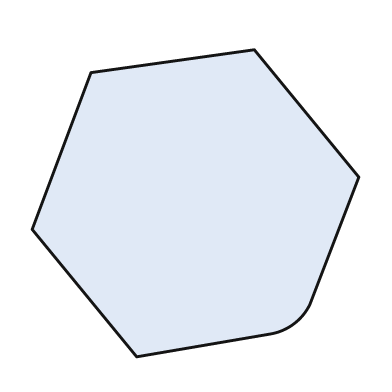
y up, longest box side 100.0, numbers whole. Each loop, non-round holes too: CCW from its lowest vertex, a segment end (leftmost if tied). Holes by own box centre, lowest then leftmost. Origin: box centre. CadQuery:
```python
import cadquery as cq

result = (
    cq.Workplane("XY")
    .moveTo(-18.0, -47.0)
    .lineTo(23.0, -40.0)
    .threePointArc((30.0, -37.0), (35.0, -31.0))
    .lineTo(50.0, 8.0)
    .lineTo(18.0, 47.0)
    .lineTo(-32.0, 40.0)
    .lineTo(-50.0, -8.0)
    .close()
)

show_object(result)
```